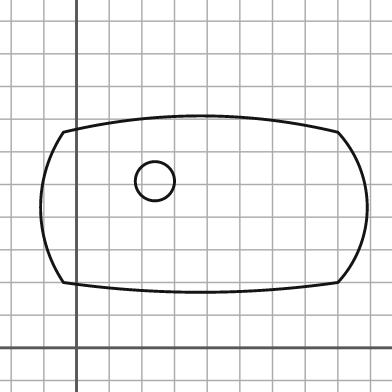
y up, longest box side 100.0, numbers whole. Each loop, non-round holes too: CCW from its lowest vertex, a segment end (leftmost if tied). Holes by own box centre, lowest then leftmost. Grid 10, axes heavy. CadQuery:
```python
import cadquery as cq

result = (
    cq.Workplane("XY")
    .moveTo(-4.0, 20.0)
    .threePointArc((38.0, 17.0), (80.0, 20.0))
    .threePointArc((89.0, 43.0), (80.0, 66.0))
    .threePointArc((38.0, 71.0), (-4.0, 66.0))
    .threePointArc((-11.0, 43.0), (-4.0, 20.0))
    .close()
    .moveTo(24.0, 51.0)
    .circle(6.0)
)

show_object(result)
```